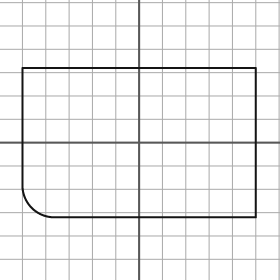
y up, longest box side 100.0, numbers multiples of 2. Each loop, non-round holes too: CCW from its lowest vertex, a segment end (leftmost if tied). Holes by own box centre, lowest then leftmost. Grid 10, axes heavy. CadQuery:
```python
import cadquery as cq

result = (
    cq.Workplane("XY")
    .moveTo(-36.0, -32.0)
    .lineTo(50.0, -32.0)
    .lineTo(50.0, 32.0)
    .lineTo(-50.0, 32.0)
    .lineTo(-50.0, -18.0)
    .threePointArc((-46.0, -28.0), (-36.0, -32.0))
    .close()
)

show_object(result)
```